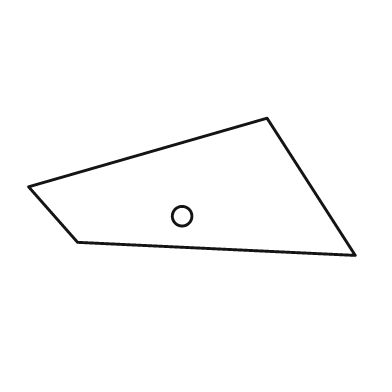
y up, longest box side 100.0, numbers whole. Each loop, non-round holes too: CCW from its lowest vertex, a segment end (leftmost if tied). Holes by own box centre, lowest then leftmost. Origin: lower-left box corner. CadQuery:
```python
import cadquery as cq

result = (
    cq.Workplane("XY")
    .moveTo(100.0, 0.0)
    .lineTo(73.0, 42.0)
    .lineTo(0.0, 21.0)
    .lineTo(15.0, 4.0)
    .close()
    .moveTo(47.0, 12.0)
    .circle(3.0)
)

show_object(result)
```